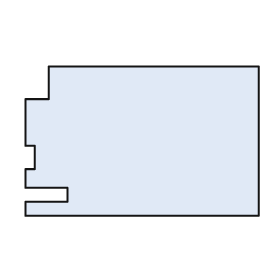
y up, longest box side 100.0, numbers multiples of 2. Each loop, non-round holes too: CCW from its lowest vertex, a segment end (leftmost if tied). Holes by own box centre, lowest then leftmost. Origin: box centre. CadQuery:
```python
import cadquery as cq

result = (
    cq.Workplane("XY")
    .moveTo(-50.0, -32.0)
    .lineTo(50.0, -32.0)
    .lineTo(50.0, 32.0)
    .lineTo(-40.0, 32.0)
    .lineTo(-40.0, 18.0)
    .lineTo(-50.0, 18.0)
    .lineTo(-50.0, -2.0)
    .lineTo(-46.0, -2.0)
    .lineTo(-46.0, -12.0)
    .lineTo(-50.0, -12.0)
    .lineTo(-50.0, -20.0)
    .lineTo(-32.0, -20.0)
    .lineTo(-32.0, -26.0)
    .lineTo(-50.0, -26.0)
    .close()
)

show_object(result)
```